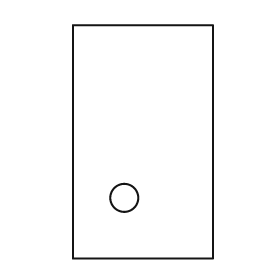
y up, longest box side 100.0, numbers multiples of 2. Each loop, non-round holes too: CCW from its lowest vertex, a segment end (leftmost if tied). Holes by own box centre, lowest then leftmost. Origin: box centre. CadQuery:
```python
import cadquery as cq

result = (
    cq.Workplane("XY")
    .moveTo(-30.0, -50.0)
    .lineTo(30.0, -50.0)
    .lineTo(30.0, 50.0)
    .lineTo(-30.0, 50.0)
    .close()
    .moveTo(-8.0, -24.0)
    .circle(6.0)
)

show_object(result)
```